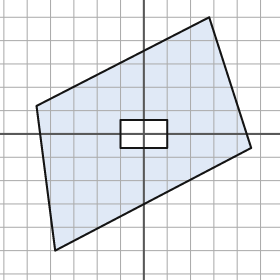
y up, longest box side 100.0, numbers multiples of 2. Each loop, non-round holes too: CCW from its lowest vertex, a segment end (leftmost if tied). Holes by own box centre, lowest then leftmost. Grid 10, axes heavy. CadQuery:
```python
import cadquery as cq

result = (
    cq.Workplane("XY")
    .moveTo(-38.0, -50.0)
    .lineTo(46.0, -6.0)
    .lineTo(28.0, 50.0)
    .lineTo(-46.0, 12.0)
    .close()
    .moveTo(-10.0, -6.0)
    .lineTo(10.0, -6.0)
    .lineTo(10.0, 6.0)
    .lineTo(-10.0, 6.0)
    .close()
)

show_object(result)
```